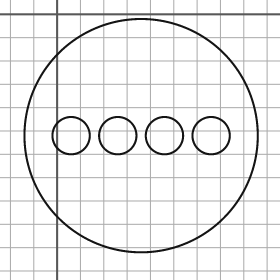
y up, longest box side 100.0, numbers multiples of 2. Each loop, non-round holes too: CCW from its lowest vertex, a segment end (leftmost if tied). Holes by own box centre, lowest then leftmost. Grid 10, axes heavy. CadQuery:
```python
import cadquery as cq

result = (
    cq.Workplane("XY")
    .moveTo(36.0, -52.0)
    .circle(50.0)
    .moveTo(6.0, -52.0)
    .circle(8.0)
    .moveTo(26.0, -52.0)
    .circle(8.0)
    .moveTo(46.0, -52.0)
    .circle(8.0)
    .moveTo(66.0, -52.0)
    .circle(8.0)
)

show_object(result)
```